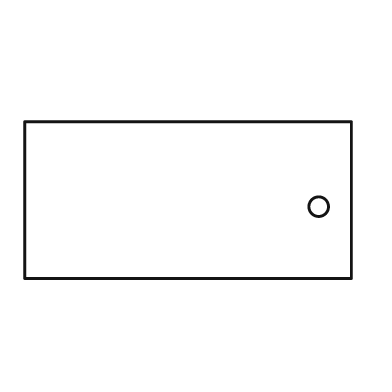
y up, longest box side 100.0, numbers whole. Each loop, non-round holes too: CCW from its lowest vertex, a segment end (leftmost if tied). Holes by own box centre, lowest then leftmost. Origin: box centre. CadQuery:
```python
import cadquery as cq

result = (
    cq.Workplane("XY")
    .moveTo(-50.0, -24.0)
    .lineTo(50.0, -24.0)
    .lineTo(50.0, 24.0)
    .lineTo(-50.0, 24.0)
    .close()
    .moveTo(40.0, -2.0)
    .circle(3.0)
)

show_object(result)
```